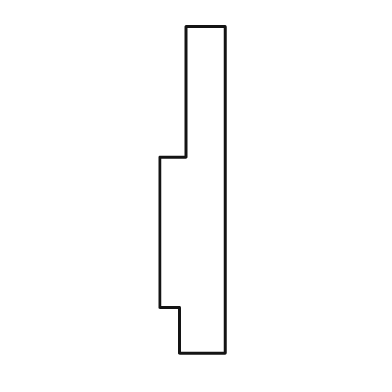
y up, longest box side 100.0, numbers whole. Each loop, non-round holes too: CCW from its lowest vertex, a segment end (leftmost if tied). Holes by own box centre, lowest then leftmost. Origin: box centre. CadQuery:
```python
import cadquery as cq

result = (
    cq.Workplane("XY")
    .moveTo(-4.0, -50.0)
    .lineTo(10.0, -50.0)
    .lineTo(10.0, 50.0)
    .lineTo(-2.0, 50.0)
    .lineTo(-2.0, 10.0)
    .lineTo(-10.0, 10.0)
    .lineTo(-10.0, -36.0)
    .lineTo(-4.0, -36.0)
    .close()
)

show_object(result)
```